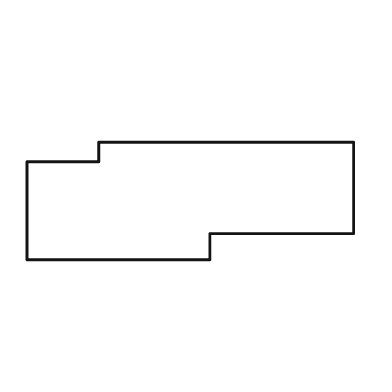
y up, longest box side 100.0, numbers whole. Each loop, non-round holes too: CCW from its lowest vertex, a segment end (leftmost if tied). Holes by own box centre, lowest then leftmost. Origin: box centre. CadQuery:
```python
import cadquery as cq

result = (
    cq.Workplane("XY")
    .moveTo(-50.0, -18.0)
    .lineTo(6.0, -18.0)
    .lineTo(6.0, -10.0)
    .lineTo(50.0, -10.0)
    .lineTo(50.0, 18.0)
    .lineTo(-28.0, 18.0)
    .lineTo(-28.0, 12.0)
    .lineTo(-50.0, 12.0)
    .close()
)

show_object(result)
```